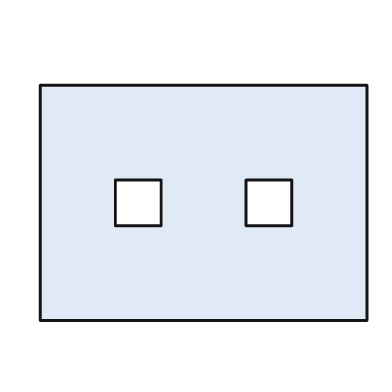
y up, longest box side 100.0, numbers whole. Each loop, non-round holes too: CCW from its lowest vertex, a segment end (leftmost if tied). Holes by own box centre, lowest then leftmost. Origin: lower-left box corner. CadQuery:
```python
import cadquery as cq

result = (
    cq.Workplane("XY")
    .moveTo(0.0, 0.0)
    .lineTo(100.0, 0.0)
    .lineTo(100.0, 72.0)
    .lineTo(0.0, 72.0)
    .close()
    .moveTo(23.0, 29.0)
    .lineTo(37.0, 29.0)
    .lineTo(37.0, 43.0)
    .lineTo(23.0, 43.0)
    .close()
    .moveTo(63.0, 29.0)
    .lineTo(77.0, 29.0)
    .lineTo(77.0, 43.0)
    .lineTo(63.0, 43.0)
    .close()
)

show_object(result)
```